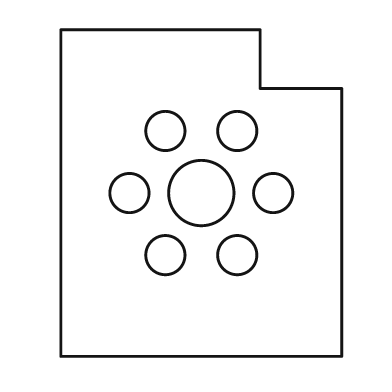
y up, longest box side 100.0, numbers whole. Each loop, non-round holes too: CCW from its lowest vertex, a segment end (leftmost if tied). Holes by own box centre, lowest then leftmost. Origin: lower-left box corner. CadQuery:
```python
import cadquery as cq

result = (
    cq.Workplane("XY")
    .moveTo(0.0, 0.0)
    .lineTo(86.0, 0.0)
    .lineTo(86.0, 82.0)
    .lineTo(61.0, 82.0)
    .lineTo(61.0, 100.0)
    .lineTo(0.0, 100.0)
    .close()
    .moveTo(32.0, 31.0)
    .circle(6.0)
    .moveTo(54.0, 31.0)
    .circle(6.0)
    .moveTo(21.0, 50.0)
    .circle(6.0)
    .moveTo(43.0, 50.0)
    .circle(10.0)
    .moveTo(65.0, 50.0)
    .circle(6.0)
    .moveTo(32.0, 69.0)
    .circle(6.0)
    .moveTo(54.0, 69.0)
    .circle(6.0)
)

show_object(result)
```